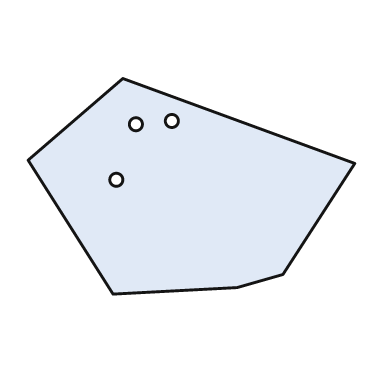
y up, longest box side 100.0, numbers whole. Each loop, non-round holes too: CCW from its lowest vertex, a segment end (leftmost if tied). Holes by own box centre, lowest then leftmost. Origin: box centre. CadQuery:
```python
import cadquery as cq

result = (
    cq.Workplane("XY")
    .moveTo(-24.0, -33.0)
    .lineTo(14.0, -31.0)
    .lineTo(28.0, -27.0)
    .lineTo(50.0, 7.0)
    .lineTo(-21.0, 33.0)
    .lineTo(-50.0, 8.0)
    .close()
    .moveTo(-23.0, 2.0)
    .circle(2.0)
    .moveTo(-17.0, 19.0)
    .circle(2.0)
    .moveTo(-6.0, 20.0)
    .circle(2.0)
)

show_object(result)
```